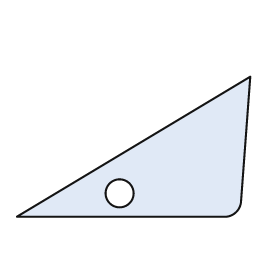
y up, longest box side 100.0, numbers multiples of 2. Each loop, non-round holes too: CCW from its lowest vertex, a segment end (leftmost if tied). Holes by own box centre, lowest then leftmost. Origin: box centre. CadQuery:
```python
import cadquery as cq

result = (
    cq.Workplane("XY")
    .moveTo(-50.0, -30.0)
    .lineTo(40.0, -30.0)
    .threePointArc((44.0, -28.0), (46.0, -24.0))
    .lineTo(50.0, 30.0)
    .close()
    .moveTo(-6.0, -20.0)
    .circle(6.0)
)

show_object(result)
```